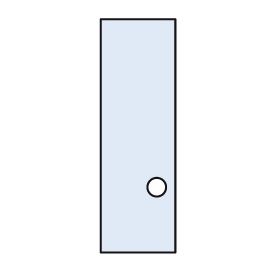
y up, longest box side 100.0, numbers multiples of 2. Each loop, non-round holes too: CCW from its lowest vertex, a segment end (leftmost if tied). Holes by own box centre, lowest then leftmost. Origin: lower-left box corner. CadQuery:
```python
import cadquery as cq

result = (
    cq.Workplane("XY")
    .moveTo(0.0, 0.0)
    .lineTo(32.0, 0.0)
    .lineTo(32.0, 100.0)
    .lineTo(0.0, 100.0)
    .close()
    .moveTo(24.0, 28.0)
    .circle(4.0)
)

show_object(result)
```